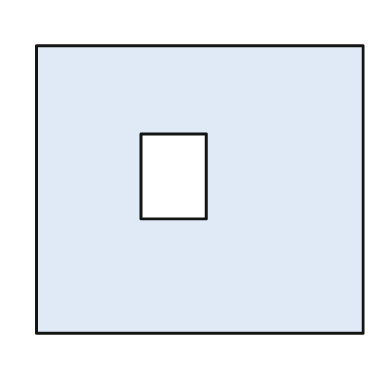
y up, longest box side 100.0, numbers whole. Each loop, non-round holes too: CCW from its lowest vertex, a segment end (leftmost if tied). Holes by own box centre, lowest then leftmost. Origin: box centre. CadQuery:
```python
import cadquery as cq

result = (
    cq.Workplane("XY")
    .moveTo(-50.0, -44.0)
    .lineTo(50.0, -44.0)
    .lineTo(50.0, 44.0)
    .lineTo(-50.0, 44.0)
    .close()
    .moveTo(-18.0, -9.0)
    .lineTo(2.0, -9.0)
    .lineTo(2.0, 17.0)
    .lineTo(-18.0, 17.0)
    .close()
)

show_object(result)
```